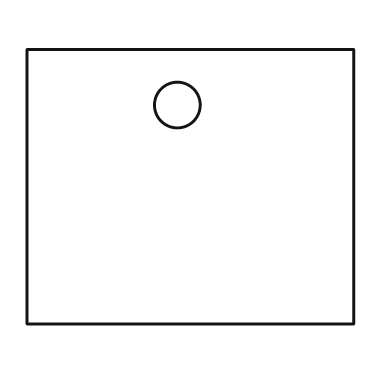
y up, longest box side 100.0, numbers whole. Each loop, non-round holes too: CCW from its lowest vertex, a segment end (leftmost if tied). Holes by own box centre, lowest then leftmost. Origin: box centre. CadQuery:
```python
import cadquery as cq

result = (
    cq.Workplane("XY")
    .moveTo(-50.0, -42.0)
    .lineTo(50.0, -42.0)
    .lineTo(50.0, 42.0)
    .lineTo(-50.0, 42.0)
    .close()
    .moveTo(-4.0, 25.0)
    .circle(7.0)
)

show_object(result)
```